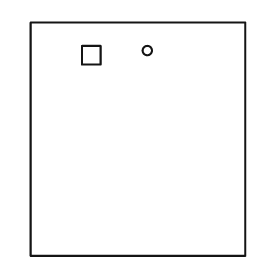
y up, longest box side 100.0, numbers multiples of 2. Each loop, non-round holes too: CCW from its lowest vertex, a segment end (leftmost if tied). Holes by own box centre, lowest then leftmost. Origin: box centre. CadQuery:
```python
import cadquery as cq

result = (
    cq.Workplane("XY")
    .moveTo(-46.0, -50.0)
    .lineTo(46.0, -50.0)
    .lineTo(46.0, 50.0)
    .lineTo(-46.0, 50.0)
    .close()
    .moveTo(-24.0, 32.0)
    .lineTo(-16.0, 32.0)
    .lineTo(-16.0, 40.0)
    .lineTo(-24.0, 40.0)
    .close()
    .moveTo(4.0, 38.0)
    .circle(2.0)
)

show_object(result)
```